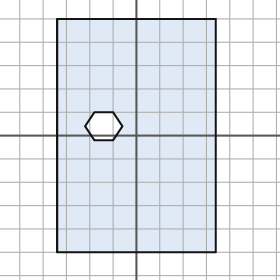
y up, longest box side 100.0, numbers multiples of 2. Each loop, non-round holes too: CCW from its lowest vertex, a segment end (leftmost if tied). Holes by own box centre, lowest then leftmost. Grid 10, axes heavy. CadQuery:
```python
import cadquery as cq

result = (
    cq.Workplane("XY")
    .moveTo(-34.0, -50.0)
    .lineTo(34.0, -50.0)
    .lineTo(34.0, 50.0)
    .lineTo(-34.0, 50.0)
    .close()
    .moveTo(-18.0, -2.0)
    .lineTo(-10.0, -2.0)
    .lineTo(-6.0, 4.0)
    .lineTo(-10.0, 10.0)
    .lineTo(-18.0, 10.0)
    .lineTo(-22.0, 4.0)
    .close()
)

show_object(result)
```